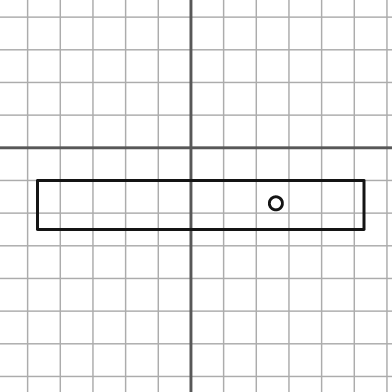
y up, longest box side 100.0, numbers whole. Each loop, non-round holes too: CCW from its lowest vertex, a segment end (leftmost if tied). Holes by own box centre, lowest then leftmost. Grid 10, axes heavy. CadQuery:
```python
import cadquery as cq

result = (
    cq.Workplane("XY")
    .moveTo(-47.0, -25.0)
    .lineTo(53.0, -25.0)
    .lineTo(53.0, -10.0)
    .lineTo(-47.0, -10.0)
    .close()
    .moveTo(26.0, -17.0)
    .circle(2.0)
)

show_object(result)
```